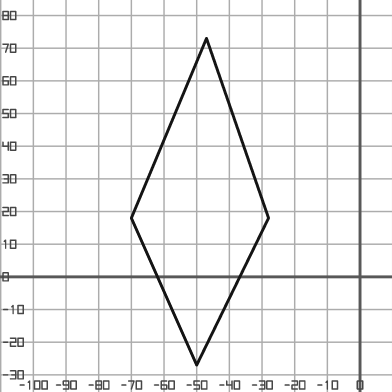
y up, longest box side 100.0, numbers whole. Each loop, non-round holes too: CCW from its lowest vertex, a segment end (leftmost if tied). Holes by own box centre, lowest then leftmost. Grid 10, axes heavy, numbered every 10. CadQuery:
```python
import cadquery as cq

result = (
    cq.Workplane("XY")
    .moveTo(-50.0, -27.0)
    .lineTo(-28.0, 18.0)
    .lineTo(-47.0, 73.0)
    .lineTo(-70.0, 18.0)
    .close()
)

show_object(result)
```